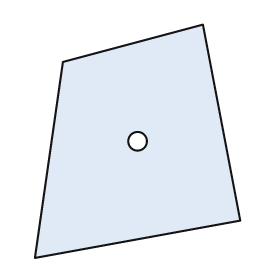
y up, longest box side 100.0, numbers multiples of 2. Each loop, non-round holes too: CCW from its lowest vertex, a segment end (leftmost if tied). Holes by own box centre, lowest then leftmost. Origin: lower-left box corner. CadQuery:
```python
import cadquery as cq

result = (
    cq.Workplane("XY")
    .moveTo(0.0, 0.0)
    .lineTo(88.0, 16.0)
    .lineTo(72.0, 100.0)
    .lineTo(12.0, 84.0)
    .close()
    .moveTo(44.0, 50.0)
    .circle(4.0)
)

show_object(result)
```